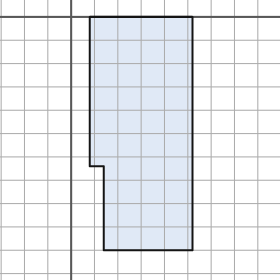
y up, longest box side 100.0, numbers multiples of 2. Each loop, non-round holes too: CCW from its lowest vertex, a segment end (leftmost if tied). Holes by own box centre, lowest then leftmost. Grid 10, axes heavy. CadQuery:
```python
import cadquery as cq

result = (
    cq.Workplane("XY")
    .moveTo(14.0, -100.0)
    .lineTo(52.0, -100.0)
    .lineTo(52.0, 0.0)
    .lineTo(8.0, 0.0)
    .lineTo(8.0, -64.0)
    .lineTo(14.0, -64.0)
    .close()
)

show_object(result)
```